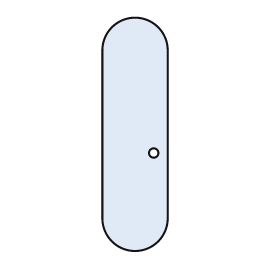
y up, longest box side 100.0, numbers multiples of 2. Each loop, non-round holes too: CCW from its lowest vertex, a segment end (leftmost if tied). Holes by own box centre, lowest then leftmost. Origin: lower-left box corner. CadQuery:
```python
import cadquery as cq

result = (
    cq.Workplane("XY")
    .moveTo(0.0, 14.0)
    .threePointArc((14.0, 0.0), (28.0, 14.0))
    .lineTo(28.0, 86.0)
    .threePointArc((14.0, 100.0), (0.0, 86.0))
    .close()
    .moveTo(22.0, 42.0)
    .circle(2.0)
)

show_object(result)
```